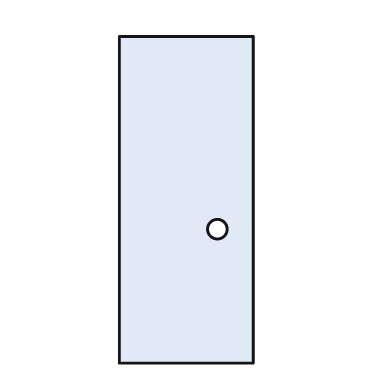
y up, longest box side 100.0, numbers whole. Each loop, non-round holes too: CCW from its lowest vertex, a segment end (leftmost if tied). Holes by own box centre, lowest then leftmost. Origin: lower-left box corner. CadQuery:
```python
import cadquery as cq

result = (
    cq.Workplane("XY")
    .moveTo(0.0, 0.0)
    .lineTo(41.0, 0.0)
    .lineTo(41.0, 100.0)
    .lineTo(0.0, 100.0)
    .close()
    .moveTo(30.0, 41.0)
    .circle(3.0)
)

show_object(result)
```